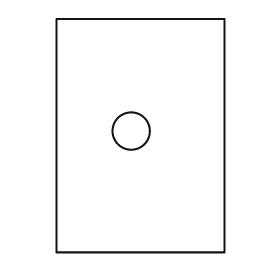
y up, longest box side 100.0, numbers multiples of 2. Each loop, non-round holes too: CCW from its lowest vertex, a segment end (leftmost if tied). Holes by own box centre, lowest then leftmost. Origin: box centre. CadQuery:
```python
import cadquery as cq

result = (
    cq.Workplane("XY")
    .moveTo(-36.0, -50.0)
    .lineTo(36.0, -50.0)
    .lineTo(36.0, 50.0)
    .lineTo(-36.0, 50.0)
    .close()
    .moveTo(-4.0, 2.0)
    .circle(8.0)
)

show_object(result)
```